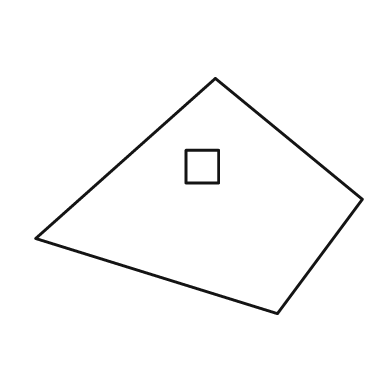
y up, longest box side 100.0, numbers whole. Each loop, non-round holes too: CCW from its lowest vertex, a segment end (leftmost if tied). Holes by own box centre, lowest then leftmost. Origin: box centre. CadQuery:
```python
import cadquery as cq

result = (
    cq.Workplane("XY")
    .moveTo(24.0, -36.0)
    .lineTo(50.0, -1.0)
    .lineTo(5.0, 36.0)
    .lineTo(-50.0, -13.0)
    .close()
    .moveTo(-4.0, 4.0)
    .lineTo(6.0, 4.0)
    .lineTo(6.0, 14.0)
    .lineTo(-4.0, 14.0)
    .close()
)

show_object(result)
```